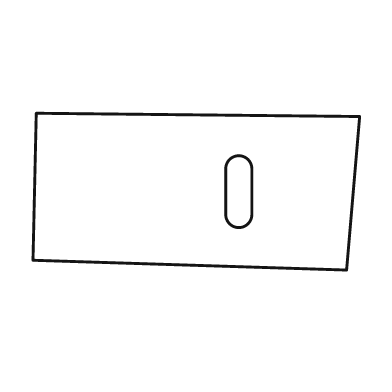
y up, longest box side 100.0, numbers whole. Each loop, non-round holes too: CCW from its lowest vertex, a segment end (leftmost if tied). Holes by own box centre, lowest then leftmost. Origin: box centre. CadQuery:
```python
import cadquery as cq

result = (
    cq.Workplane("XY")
    .moveTo(46.0, -24.0)
    .lineTo(50.0, 23.0)
    .lineTo(-49.0, 24.0)
    .lineTo(-50.0, -21.0)
    .close()
    .moveTo(9.0, -7.0)
    .threePointArc((13.0, -11.0), (17.0, -7.0))
    .lineTo(17.0, 7.0)
    .threePointArc((13.0, 11.0), (9.0, 7.0))
    .close()
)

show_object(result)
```